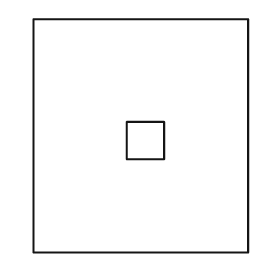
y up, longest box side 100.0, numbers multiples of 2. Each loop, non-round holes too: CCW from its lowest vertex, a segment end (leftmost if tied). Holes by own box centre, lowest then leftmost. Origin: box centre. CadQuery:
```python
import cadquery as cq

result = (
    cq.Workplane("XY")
    .moveTo(-46.0, -50.0)
    .lineTo(46.0, -50.0)
    .lineTo(46.0, 50.0)
    .lineTo(-46.0, 50.0)
    .close()
    .moveTo(-6.0, -10.0)
    .lineTo(10.0, -10.0)
    .lineTo(10.0, 6.0)
    .lineTo(-6.0, 6.0)
    .close()
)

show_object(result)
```